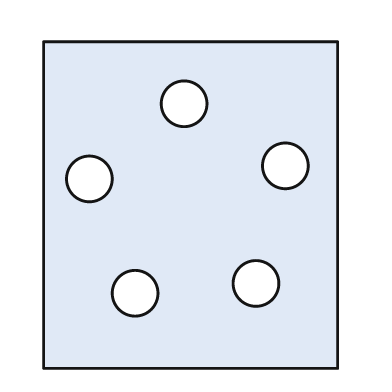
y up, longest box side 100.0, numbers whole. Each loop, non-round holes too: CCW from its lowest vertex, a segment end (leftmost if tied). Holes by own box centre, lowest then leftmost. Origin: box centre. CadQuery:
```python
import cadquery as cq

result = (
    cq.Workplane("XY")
    .moveTo(-45.0, -50.0)
    .lineTo(45.0, -50.0)
    .lineTo(45.0, 50.0)
    .lineTo(-45.0, 50.0)
    .close()
    .moveTo(-17.0, -27.0)
    .circle(7.0)
    .moveTo(20.0, -24.0)
    .circle(7.0)
    .moveTo(-31.0, 8.0)
    .circle(7.0)
    .moveTo(29.0, 12.0)
    .circle(7.0)
    .moveTo(-2.0, 31.0)
    .circle(7.0)
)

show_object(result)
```